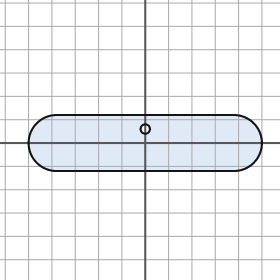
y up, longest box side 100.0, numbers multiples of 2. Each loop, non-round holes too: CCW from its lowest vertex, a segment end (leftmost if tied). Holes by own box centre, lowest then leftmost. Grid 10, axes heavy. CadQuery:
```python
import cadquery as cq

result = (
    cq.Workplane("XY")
    .moveTo(-38.0, -12.0)
    .lineTo(38.0, -12.0)
    .threePointArc((50.0, 0.0), (38.0, 12.0))
    .lineTo(-38.0, 12.0)
    .threePointArc((-50.0, 0.0), (-38.0, -12.0))
    .close()
    .moveTo(0.0, 6.0)
    .circle(2.0)
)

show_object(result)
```